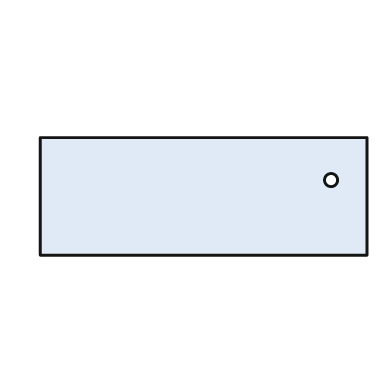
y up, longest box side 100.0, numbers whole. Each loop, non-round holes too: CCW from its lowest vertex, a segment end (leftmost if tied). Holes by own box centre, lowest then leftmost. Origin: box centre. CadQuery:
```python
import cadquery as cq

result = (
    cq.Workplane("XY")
    .moveTo(-50.0, -18.0)
    .lineTo(50.0, -18.0)
    .lineTo(50.0, 18.0)
    .lineTo(-50.0, 18.0)
    .close()
    .moveTo(39.0, 5.0)
    .circle(2.0)
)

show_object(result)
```